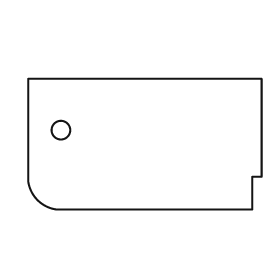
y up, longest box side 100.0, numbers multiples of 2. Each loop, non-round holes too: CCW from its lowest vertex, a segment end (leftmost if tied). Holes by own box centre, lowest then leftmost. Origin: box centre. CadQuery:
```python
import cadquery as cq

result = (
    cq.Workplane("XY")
    .moveTo(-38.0, -28.0)
    .lineTo(46.0, -28.0)
    .lineTo(46.0, -14.0)
    .lineTo(50.0, -14.0)
    .lineTo(50.0, 28.0)
    .lineTo(-50.0, 28.0)
    .lineTo(-50.0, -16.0)
    .threePointArc((-46.0, -24.0), (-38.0, -28.0))
    .close()
    .moveTo(-36.0, 6.0)
    .circle(4.0)
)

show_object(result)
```